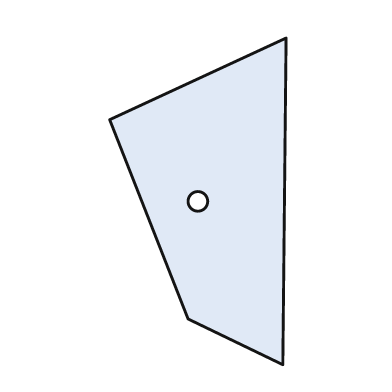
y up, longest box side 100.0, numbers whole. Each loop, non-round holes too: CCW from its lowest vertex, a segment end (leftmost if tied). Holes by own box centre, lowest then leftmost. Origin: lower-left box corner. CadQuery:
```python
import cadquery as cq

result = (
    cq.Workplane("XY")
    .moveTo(53.0, 0.0)
    .lineTo(54.0, 100.0)
    .lineTo(0.0, 75.0)
    .lineTo(24.0, 14.0)
    .close()
    .moveTo(27.0, 50.0)
    .circle(3.0)
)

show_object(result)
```